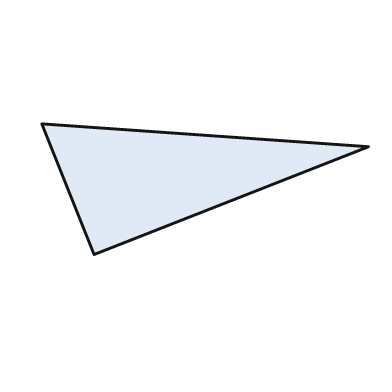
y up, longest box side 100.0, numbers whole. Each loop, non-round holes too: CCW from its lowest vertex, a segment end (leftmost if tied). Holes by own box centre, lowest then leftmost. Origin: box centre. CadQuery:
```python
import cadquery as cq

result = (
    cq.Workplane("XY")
    .moveTo(-34.0, -20.0)
    .lineTo(50.0, 13.0)
    .lineTo(-50.0, 20.0)
    .close()
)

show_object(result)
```